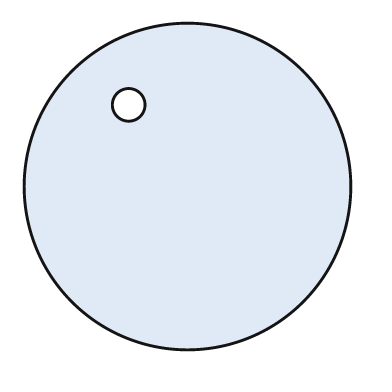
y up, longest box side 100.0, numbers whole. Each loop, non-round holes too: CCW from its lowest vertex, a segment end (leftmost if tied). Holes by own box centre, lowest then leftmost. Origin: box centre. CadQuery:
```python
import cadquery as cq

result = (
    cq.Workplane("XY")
    .moveTo(0.0, 0.0)
    .circle(50.0)
    .moveTo(-18.0, 25.0)
    .circle(5.0)
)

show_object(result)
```